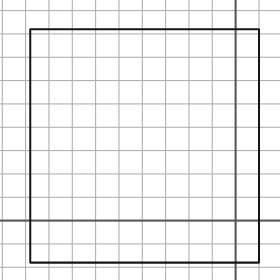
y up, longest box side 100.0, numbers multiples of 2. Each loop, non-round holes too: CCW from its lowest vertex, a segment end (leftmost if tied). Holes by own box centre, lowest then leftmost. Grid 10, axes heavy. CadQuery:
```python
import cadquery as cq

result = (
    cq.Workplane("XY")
    .moveTo(-88.0, -18.0)
    .lineTo(10.0, -18.0)
    .lineTo(10.0, 82.0)
    .lineTo(-88.0, 82.0)
    .close()
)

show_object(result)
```